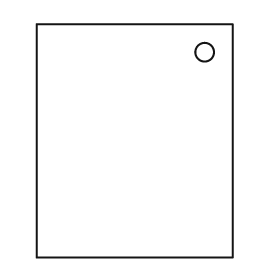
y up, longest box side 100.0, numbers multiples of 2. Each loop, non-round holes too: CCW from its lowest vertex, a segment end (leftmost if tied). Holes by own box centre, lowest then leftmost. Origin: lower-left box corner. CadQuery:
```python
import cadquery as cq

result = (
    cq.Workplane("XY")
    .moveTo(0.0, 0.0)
    .lineTo(84.0, 0.0)
    .lineTo(84.0, 100.0)
    .lineTo(0.0, 100.0)
    .close()
    .moveTo(72.0, 88.0)
    .circle(4.0)
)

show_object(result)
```